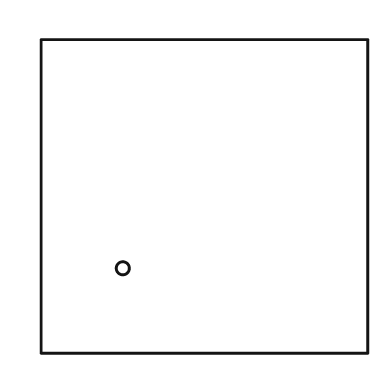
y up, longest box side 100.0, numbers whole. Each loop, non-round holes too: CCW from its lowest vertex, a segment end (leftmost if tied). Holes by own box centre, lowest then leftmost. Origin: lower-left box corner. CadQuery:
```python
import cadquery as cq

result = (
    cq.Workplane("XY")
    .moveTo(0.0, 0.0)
    .lineTo(100.0, 0.0)
    .lineTo(100.0, 96.0)
    .lineTo(0.0, 96.0)
    .close()
    .moveTo(25.0, 26.0)
    .circle(2.0)
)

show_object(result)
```